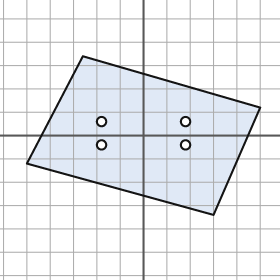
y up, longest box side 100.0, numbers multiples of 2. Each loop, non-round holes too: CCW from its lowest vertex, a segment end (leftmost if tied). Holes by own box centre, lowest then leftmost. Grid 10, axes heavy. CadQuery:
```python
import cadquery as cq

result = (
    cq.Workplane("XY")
    .moveTo(30.0, -34.0)
    .lineTo(50.0, 12.0)
    .lineTo(-26.0, 34.0)
    .lineTo(-50.0, -12.0)
    .close()
    .moveTo(-18.0, -4.0)
    .circle(2.0)
    .moveTo(18.0, -4.0)
    .circle(2.0)
    .moveTo(-18.0, 6.0)
    .circle(2.0)
    .moveTo(18.0, 6.0)
    .circle(2.0)
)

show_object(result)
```